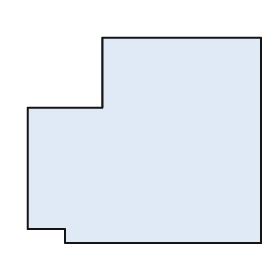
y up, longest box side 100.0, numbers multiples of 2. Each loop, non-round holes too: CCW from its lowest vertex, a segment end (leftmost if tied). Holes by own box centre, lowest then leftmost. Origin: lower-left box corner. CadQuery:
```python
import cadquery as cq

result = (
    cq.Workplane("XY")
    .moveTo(16.0, 0.0)
    .lineTo(100.0, 0.0)
    .lineTo(100.0, 88.0)
    .lineTo(32.0, 88.0)
    .lineTo(32.0, 58.0)
    .lineTo(0.0, 58.0)
    .lineTo(0.0, 6.0)
    .lineTo(16.0, 6.0)
    .close()
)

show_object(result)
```